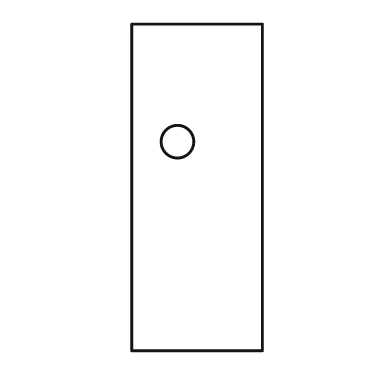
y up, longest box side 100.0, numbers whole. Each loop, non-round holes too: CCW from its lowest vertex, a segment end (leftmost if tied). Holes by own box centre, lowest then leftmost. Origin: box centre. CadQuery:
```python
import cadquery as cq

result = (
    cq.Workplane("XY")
    .moveTo(-20.0, -50.0)
    .lineTo(20.0, -50.0)
    .lineTo(20.0, 50.0)
    .lineTo(-20.0, 50.0)
    .close()
    .moveTo(-6.0, 14.0)
    .circle(5.0)
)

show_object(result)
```